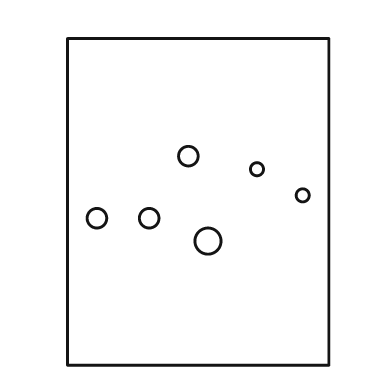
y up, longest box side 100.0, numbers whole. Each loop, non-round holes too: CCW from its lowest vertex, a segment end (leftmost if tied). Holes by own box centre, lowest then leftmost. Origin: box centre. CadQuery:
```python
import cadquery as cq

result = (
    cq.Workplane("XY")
    .moveTo(-40.0, -50.0)
    .lineTo(40.0, -50.0)
    .lineTo(40.0, 50.0)
    .lineTo(-40.0, 50.0)
    .close()
    .moveTo(3.0, -12.0)
    .circle(4.0)
    .moveTo(-31.0, -5.0)
    .circle(3.0)
    .moveTo(-15.0, -5.0)
    .circle(3.0)
    .moveTo(32.0, 2.0)
    .circle(2.0)
    .moveTo(18.0, 10.0)
    .circle(2.0)
    .moveTo(-3.0, 14.0)
    .circle(3.0)
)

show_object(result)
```